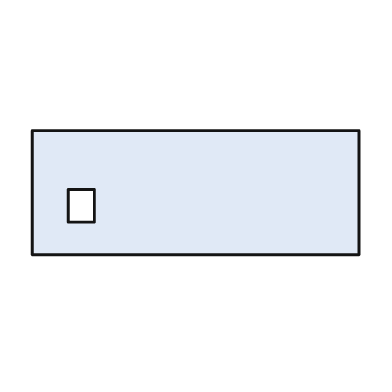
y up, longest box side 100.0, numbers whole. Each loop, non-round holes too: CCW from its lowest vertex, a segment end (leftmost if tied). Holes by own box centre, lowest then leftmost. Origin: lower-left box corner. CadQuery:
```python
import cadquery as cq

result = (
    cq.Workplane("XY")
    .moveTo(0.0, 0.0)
    .lineTo(100.0, 0.0)
    .lineTo(100.0, 38.0)
    .lineTo(0.0, 38.0)
    .close()
    .moveTo(11.0, 10.0)
    .lineTo(19.0, 10.0)
    .lineTo(19.0, 20.0)
    .lineTo(11.0, 20.0)
    .close()
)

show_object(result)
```